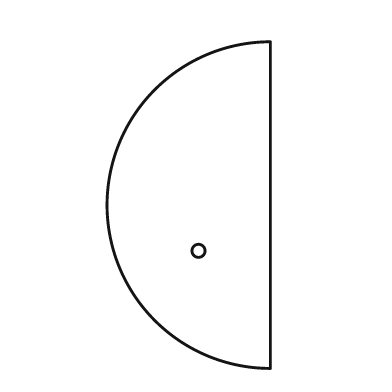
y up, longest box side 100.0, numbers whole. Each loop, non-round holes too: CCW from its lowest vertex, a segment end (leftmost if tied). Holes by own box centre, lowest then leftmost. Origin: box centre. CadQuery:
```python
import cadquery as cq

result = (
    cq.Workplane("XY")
    .moveTo(25.0, -50.0)
    .lineTo(25.0, 50.0)
    .threePointArc((-25.0, 0.0), (25.0, -50.0))
    .close()
    .moveTo(3.0, -14.0)
    .circle(2.0)
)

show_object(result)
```